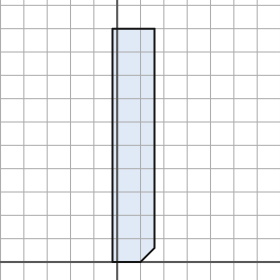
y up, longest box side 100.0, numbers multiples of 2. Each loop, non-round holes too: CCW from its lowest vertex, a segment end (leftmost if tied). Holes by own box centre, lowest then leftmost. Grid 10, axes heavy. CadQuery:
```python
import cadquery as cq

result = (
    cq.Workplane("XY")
    .moveTo(-2.0, 0.0)
    .lineTo(10.0, 0.0)
    .lineTo(16.0, 6.0)
    .lineTo(16.0, 100.0)
    .lineTo(-2.0, 100.0)
    .close()
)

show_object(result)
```